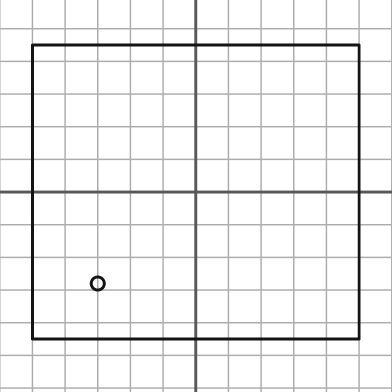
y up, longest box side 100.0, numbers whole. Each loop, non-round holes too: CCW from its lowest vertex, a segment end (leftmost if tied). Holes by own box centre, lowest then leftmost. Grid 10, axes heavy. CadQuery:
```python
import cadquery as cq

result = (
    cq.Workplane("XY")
    .moveTo(-50.0, -45.0)
    .lineTo(50.0, -45.0)
    .lineTo(50.0, 45.0)
    .lineTo(-50.0, 45.0)
    .close()
    .moveTo(-30.0, -28.0)
    .circle(2.0)
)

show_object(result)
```